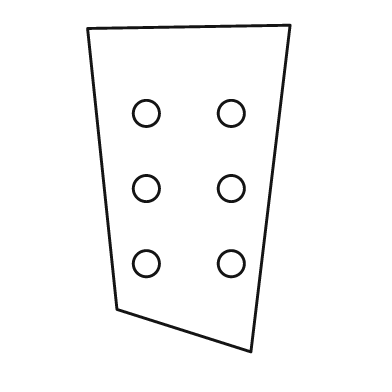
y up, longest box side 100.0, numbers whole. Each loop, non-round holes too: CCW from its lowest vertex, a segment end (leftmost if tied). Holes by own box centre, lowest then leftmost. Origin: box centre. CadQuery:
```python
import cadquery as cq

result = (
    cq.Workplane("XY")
    .moveTo(19.0, -50.0)
    .lineTo(31.0, 50.0)
    .lineTo(-31.0, 49.0)
    .lineTo(-22.0, -37.0)
    .close()
    .moveTo(-13.0, -23.0)
    .circle(4.0)
    .moveTo(13.0, -23.0)
    .circle(4.0)
    .moveTo(-13.0, 0.0)
    .circle(4.0)
    .moveTo(13.0, 0.0)
    .circle(4.0)
    .moveTo(-13.0, 23.0)
    .circle(4.0)
    .moveTo(13.0, 23.0)
    .circle(4.0)
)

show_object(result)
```